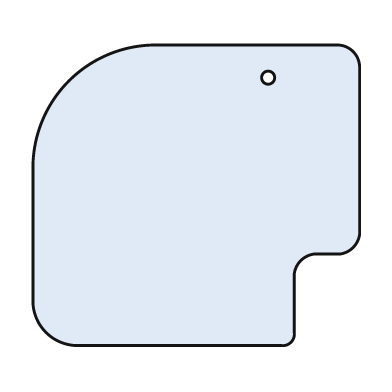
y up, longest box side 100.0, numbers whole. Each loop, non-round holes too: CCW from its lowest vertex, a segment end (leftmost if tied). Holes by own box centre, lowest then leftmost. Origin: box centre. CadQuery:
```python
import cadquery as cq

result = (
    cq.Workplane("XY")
    .moveTo(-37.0, -46.0)
    .lineTo(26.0, -46.0)
    .threePointArc((29.0, -45.0), (30.0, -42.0))
    .lineTo(30.0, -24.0)
    .threePointArc((32.0, -20.0), (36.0, -18.0))
    .lineTo(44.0, -18.0)
    .threePointArc((48.0, -16.0), (50.0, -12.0))
    .lineTo(50.0, 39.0)
    .threePointArc((48.0, 44.0), (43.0, 46.0))
    .lineTo(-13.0, 46.0)
    .threePointArc((-39.0, 35.0), (-50.0, 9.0))
    .lineTo(-50.0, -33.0)
    .threePointArc((-46.0, -42.0), (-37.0, -46.0))
    .close()
    .moveTo(22.0, 36.0)
    .circle(2.0)
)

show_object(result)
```